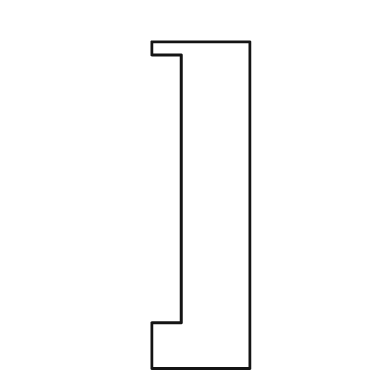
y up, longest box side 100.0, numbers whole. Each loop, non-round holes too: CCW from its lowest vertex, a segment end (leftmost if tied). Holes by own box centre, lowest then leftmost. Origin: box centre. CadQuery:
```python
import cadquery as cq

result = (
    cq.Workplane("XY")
    .moveTo(-15.0, -50.0)
    .lineTo(15.0, -50.0)
    .lineTo(15.0, 50.0)
    .lineTo(-15.0, 50.0)
    .lineTo(-15.0, 46.0)
    .lineTo(-6.0, 46.0)
    .lineTo(-6.0, -36.0)
    .lineTo(-15.0, -36.0)
    .close()
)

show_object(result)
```